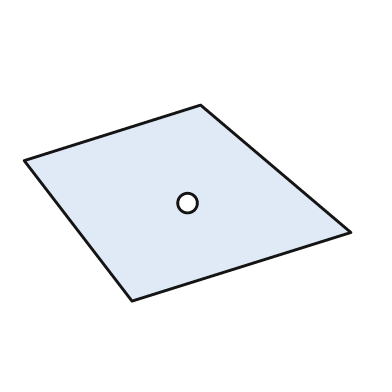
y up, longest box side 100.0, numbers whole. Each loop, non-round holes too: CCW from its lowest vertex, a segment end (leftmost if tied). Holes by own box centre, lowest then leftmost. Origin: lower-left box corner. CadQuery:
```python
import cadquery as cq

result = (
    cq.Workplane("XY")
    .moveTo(33.0, 0.0)
    .lineTo(100.0, 21.0)
    .lineTo(54.0, 60.0)
    .lineTo(0.0, 43.0)
    .close()
    .moveTo(50.0, 30.0)
    .circle(3.0)
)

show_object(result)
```